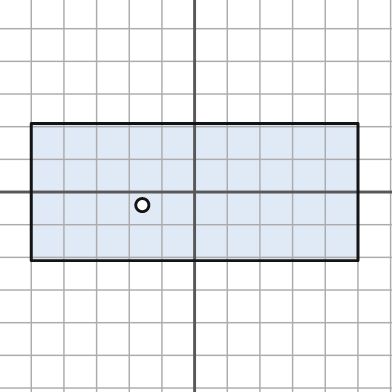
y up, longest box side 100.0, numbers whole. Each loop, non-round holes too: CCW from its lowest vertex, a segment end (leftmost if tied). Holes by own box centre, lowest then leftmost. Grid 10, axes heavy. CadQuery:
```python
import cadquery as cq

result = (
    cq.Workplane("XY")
    .moveTo(-50.0, -21.0)
    .lineTo(50.0, -21.0)
    .lineTo(50.0, 21.0)
    .lineTo(-50.0, 21.0)
    .close()
    .moveTo(-16.0, -4.0)
    .circle(2.0)
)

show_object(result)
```